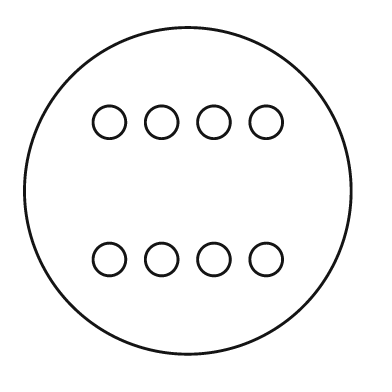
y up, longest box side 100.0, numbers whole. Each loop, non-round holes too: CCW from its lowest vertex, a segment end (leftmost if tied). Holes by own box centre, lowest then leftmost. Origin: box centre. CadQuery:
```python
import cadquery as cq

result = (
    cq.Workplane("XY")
    .moveTo(0.0, 0.0)
    .circle(50.0)
    .moveTo(-24.0, -21.0)
    .circle(5.0)
    .moveTo(-8.0, -21.0)
    .circle(5.0)
    .moveTo(8.0, -21.0)
    .circle(5.0)
    .moveTo(24.0, -21.0)
    .circle(5.0)
    .moveTo(-24.0, 21.0)
    .circle(5.0)
    .moveTo(-8.0, 21.0)
    .circle(5.0)
    .moveTo(8.0, 21.0)
    .circle(5.0)
    .moveTo(24.0, 21.0)
    .circle(5.0)
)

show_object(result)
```